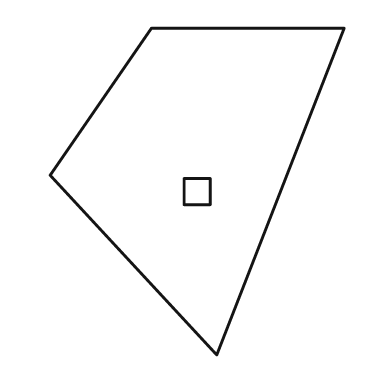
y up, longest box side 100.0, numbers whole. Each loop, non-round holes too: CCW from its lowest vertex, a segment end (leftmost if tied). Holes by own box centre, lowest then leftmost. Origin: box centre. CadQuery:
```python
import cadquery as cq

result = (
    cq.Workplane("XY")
    .moveTo(6.0, -50.0)
    .lineTo(45.0, 50.0)
    .lineTo(-14.0, 50.0)
    .lineTo(-45.0, 5.0)
    .close()
    .moveTo(-4.0, -4.0)
    .lineTo(4.0, -4.0)
    .lineTo(4.0, 4.0)
    .lineTo(-4.0, 4.0)
    .close()
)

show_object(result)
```